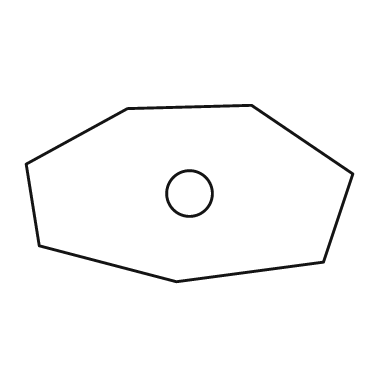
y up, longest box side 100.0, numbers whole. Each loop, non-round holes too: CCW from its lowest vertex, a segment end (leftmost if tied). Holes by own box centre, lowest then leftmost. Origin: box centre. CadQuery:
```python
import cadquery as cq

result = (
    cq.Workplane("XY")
    .moveTo(-4.0, -27.0)
    .lineTo(41.0, -21.0)
    .lineTo(50.0, 6.0)
    .lineTo(19.0, 27.0)
    .lineTo(-19.0, 26.0)
    .lineTo(-50.0, 9.0)
    .lineTo(-46.0, -16.0)
    .close()
    .moveTo(0.0, 0.0)
    .circle(7.0)
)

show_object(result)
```